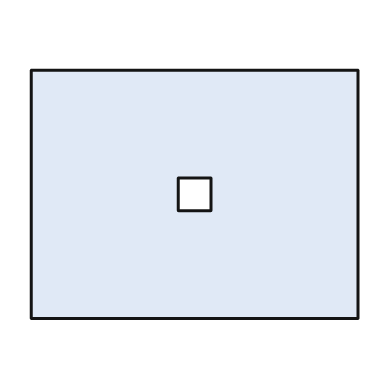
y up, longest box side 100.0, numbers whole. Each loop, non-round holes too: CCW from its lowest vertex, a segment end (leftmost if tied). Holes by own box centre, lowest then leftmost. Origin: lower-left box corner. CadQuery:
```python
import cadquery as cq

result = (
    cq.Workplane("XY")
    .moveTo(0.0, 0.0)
    .lineTo(100.0, 0.0)
    .lineTo(100.0, 76.0)
    .lineTo(0.0, 76.0)
    .close()
    .moveTo(45.0, 33.0)
    .lineTo(55.0, 33.0)
    .lineTo(55.0, 43.0)
    .lineTo(45.0, 43.0)
    .close()
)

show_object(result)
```